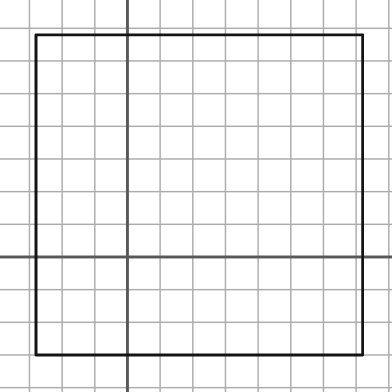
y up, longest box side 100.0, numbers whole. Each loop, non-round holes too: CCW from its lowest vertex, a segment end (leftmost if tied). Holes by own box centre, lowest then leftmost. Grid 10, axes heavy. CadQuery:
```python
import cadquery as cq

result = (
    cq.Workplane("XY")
    .moveTo(-28.0, -30.0)
    .lineTo(72.0, -30.0)
    .lineTo(72.0, 68.0)
    .lineTo(-28.0, 68.0)
    .close()
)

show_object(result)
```